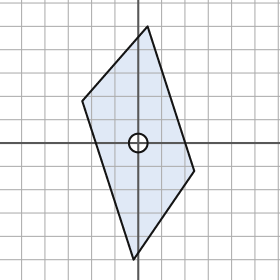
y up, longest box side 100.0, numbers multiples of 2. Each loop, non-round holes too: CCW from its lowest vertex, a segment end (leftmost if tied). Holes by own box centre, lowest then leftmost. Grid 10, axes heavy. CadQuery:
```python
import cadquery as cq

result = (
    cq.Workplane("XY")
    .moveTo(-2.0, -50.0)
    .lineTo(24.0, -12.0)
    .lineTo(4.0, 50.0)
    .lineTo(-24.0, 18.0)
    .close()
    .moveTo(0.0, 0.0)
    .circle(4.0)
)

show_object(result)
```